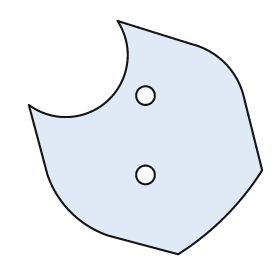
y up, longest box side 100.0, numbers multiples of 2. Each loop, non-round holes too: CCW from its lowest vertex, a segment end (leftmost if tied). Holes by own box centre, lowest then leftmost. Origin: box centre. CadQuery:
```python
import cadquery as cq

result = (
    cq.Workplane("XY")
    .moveTo(14.0, -50.0)
    .threePointArc((34.0, -34.0), (50.0, -14.0))
    .lineTo(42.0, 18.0)
    .threePointArc((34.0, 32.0), (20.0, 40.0))
    .lineTo(-12.0, 50.0)
    .threePointArc((-16.0, 16.0), (-50.0, 14.0))
    .lineTo(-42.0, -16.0)
    .threePointArc((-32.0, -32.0), (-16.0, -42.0))
    .close()
    .moveTo(0.0, -16.0)
    .circle(4.0)
    .moveTo(0.0, 18.0)
    .circle(4.0)
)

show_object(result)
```